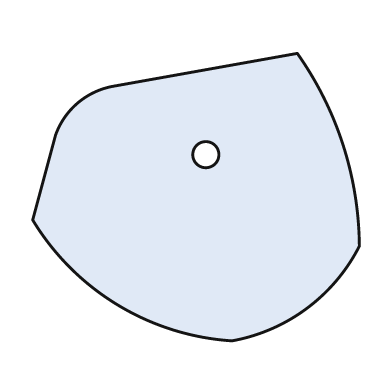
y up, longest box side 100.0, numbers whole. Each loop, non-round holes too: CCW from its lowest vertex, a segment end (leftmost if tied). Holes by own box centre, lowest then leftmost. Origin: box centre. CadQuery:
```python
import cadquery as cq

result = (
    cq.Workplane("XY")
    .moveTo(11.0, -44.0)
    .threePointArc((34.0, -34.0), (50.0, -15.0))
    .threePointArc((45.0, 16.0), (31.0, 44.0))
    .lineTo(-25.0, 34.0)
    .threePointArc((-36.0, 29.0), (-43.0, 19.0))
    .lineTo(-50.0, -7.0)
    .threePointArc((-24.0, -33.0), (11.0, -44.0))
    .close()
    .moveTo(3.0, 13.0)
    .circle(4.0)
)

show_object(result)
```